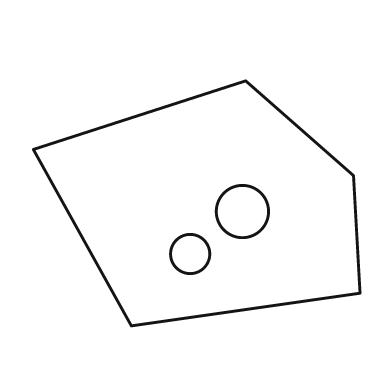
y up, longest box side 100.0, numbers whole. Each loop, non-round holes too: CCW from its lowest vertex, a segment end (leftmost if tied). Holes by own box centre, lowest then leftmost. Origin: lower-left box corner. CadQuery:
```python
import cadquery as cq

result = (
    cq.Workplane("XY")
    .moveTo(30.0, 0.0)
    .lineTo(100.0, 10.0)
    .lineTo(98.0, 46.0)
    .lineTo(65.0, 75.0)
    .lineTo(0.0, 54.0)
    .close()
    .moveTo(48.0, 22.0)
    .circle(6.0)
    .moveTo(64.0, 35.0)
    .circle(8.0)
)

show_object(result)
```